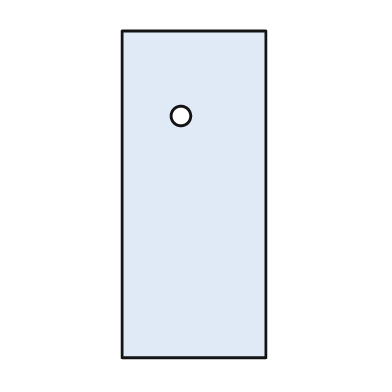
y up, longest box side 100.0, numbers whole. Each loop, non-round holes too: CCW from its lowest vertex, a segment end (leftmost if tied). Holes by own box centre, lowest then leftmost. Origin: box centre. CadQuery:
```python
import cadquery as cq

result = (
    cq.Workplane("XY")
    .moveTo(-22.0, -50.0)
    .lineTo(22.0, -50.0)
    .lineTo(22.0, 50.0)
    .lineTo(-22.0, 50.0)
    .close()
    .moveTo(-4.0, 24.0)
    .circle(3.0)
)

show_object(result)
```